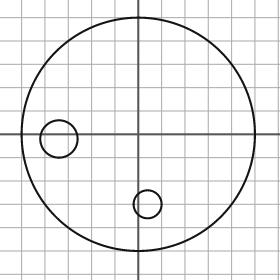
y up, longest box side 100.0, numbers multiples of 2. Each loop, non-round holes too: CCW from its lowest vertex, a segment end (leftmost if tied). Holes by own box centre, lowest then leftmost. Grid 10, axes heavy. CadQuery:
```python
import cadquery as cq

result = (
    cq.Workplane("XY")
    .moveTo(0.0, 0.0)
    .circle(50.0)
    .moveTo(4.0, -30.0)
    .circle(6.0)
    .moveTo(-34.0, -2.0)
    .circle(8.0)
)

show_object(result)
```